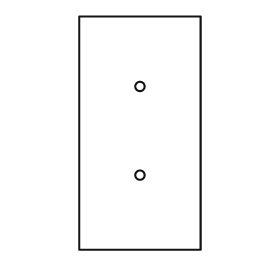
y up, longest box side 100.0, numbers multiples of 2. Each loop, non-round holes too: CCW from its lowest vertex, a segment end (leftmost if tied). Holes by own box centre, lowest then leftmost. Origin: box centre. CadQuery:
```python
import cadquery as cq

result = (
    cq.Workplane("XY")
    .moveTo(-26.0, -50.0)
    .lineTo(26.0, -50.0)
    .lineTo(26.0, 50.0)
    .lineTo(-26.0, 50.0)
    .close()
    .moveTo(0.0, -18.0)
    .circle(2.0)
    .moveTo(0.0, 20.0)
    .circle(2.0)
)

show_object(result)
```